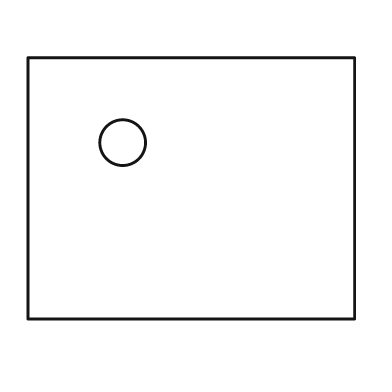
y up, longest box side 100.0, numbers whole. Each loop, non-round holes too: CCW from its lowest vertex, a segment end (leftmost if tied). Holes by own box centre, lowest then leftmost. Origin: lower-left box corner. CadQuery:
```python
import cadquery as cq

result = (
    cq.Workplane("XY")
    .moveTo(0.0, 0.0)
    .lineTo(100.0, 0.0)
    .lineTo(100.0, 80.0)
    .lineTo(0.0, 80.0)
    .close()
    .moveTo(29.0, 54.0)
    .circle(7.0)
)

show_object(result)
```